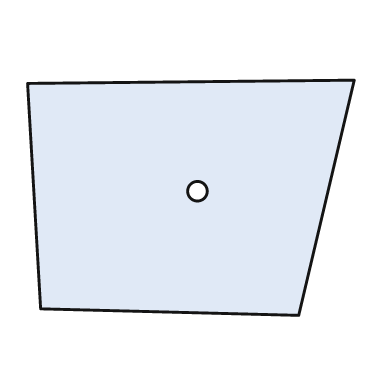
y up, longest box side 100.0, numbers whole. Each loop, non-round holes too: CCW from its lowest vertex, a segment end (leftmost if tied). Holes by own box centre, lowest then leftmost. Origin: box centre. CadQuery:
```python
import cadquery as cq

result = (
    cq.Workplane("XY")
    .moveTo(33.0, -36.0)
    .lineTo(50.0, 36.0)
    .lineTo(-50.0, 35.0)
    .lineTo(-46.0, -34.0)
    .close()
    .moveTo(2.0, 2.0)
    .circle(3.0)
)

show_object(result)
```